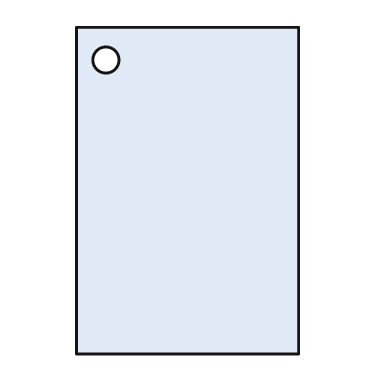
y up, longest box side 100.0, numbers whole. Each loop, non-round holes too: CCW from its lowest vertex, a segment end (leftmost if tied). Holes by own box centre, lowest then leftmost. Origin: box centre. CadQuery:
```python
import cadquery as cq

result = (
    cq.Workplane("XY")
    .moveTo(-34.0, -50.0)
    .lineTo(34.0, -50.0)
    .lineTo(34.0, 50.0)
    .lineTo(-34.0, 50.0)
    .close()
    .moveTo(-25.0, 40.0)
    .circle(4.0)
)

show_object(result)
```